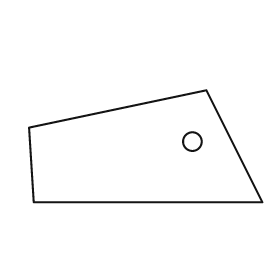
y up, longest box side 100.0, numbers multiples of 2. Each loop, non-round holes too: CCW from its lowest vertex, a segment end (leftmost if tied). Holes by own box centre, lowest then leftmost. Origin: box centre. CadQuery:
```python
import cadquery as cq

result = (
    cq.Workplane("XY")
    .moveTo(-48.0, -24.0)
    .lineTo(50.0, -24.0)
    .lineTo(26.0, 24.0)
    .lineTo(-50.0, 8.0)
    .close()
    .moveTo(20.0, 2.0)
    .circle(4.0)
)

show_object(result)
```